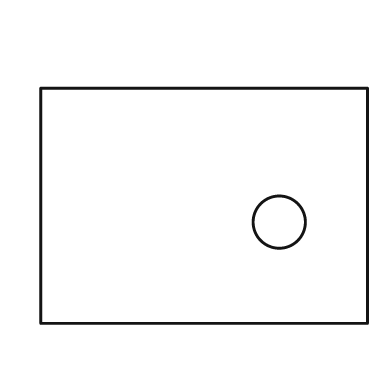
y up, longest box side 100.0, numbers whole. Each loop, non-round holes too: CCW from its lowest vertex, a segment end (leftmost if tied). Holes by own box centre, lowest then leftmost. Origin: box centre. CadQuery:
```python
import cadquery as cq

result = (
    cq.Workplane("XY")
    .moveTo(-50.0, -36.0)
    .lineTo(50.0, -36.0)
    .lineTo(50.0, 36.0)
    .lineTo(-50.0, 36.0)
    .close()
    .moveTo(23.0, -5.0)
    .circle(8.0)
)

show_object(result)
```